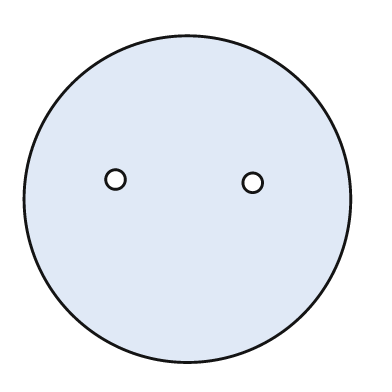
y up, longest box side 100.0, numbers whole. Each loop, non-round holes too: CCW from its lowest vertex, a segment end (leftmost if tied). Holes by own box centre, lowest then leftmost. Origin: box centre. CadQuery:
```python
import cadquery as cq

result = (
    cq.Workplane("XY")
    .moveTo(0.0, 0.0)
    .circle(50.0)
    .moveTo(20.0, 5.0)
    .circle(3.0)
    .moveTo(-22.0, 6.0)
    .circle(3.0)
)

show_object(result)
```